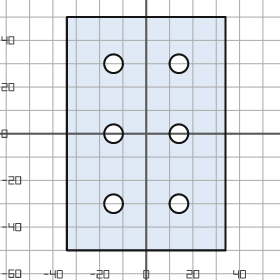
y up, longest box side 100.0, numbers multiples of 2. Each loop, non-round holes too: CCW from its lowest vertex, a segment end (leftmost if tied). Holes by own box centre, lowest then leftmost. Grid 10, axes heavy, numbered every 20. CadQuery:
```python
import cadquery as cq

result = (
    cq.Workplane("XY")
    .moveTo(-34.0, -50.0)
    .lineTo(34.0, -50.0)
    .lineTo(34.0, 50.0)
    .lineTo(-34.0, 50.0)
    .close()
    .moveTo(-14.0, -30.0)
    .circle(4.0)
    .moveTo(14.0, -30.0)
    .circle(4.0)
    .moveTo(-14.0, 0.0)
    .circle(4.0)
    .moveTo(14.0, 0.0)
    .circle(4.0)
    .moveTo(-14.0, 30.0)
    .circle(4.0)
    .moveTo(14.0, 30.0)
    .circle(4.0)
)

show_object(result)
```